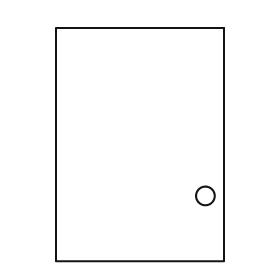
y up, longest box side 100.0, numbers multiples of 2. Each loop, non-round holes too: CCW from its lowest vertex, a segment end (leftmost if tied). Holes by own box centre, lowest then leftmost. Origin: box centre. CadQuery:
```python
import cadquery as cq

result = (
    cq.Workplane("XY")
    .moveTo(-36.0, -50.0)
    .lineTo(36.0, -50.0)
    .lineTo(36.0, 50.0)
    .lineTo(-36.0, 50.0)
    .close()
    .moveTo(28.0, -22.0)
    .circle(4.0)
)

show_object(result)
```